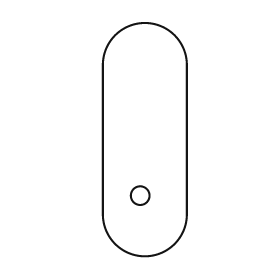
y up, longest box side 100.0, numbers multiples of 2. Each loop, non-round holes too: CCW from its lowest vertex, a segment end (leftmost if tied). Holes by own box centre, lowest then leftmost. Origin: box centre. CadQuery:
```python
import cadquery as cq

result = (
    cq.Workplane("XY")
    .moveTo(-18.0, -32.0)
    .threePointArc((0.0, -50.0), (18.0, -32.0))
    .lineTo(18.0, 32.0)
    .threePointArc((0.0, 50.0), (-18.0, 32.0))
    .close()
    .moveTo(-2.0, -24.0)
    .circle(4.0)
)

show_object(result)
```